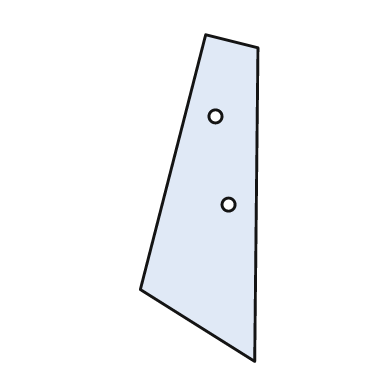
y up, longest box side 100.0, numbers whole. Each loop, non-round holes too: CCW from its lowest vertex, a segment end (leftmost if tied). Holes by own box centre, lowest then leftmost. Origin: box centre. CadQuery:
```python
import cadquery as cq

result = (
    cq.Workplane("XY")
    .moveTo(17.0, -50.0)
    .lineTo(18.0, 46.0)
    .lineTo(2.0, 50.0)
    .lineTo(-18.0, -28.0)
    .close()
    .moveTo(9.0, -2.0)
    .circle(2.0)
    .moveTo(5.0, 25.0)
    .circle(2.0)
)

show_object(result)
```